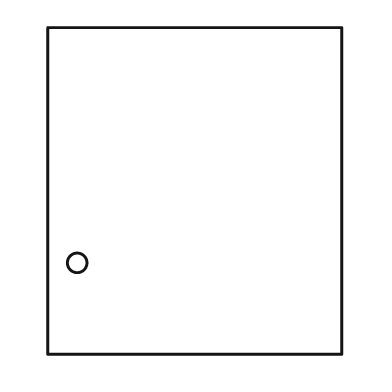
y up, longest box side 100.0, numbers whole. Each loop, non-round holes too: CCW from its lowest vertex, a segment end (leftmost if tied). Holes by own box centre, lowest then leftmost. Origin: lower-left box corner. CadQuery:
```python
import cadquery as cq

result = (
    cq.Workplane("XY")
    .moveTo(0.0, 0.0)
    .lineTo(90.0, 0.0)
    .lineTo(90.0, 100.0)
    .lineTo(0.0, 100.0)
    .close()
    .moveTo(9.0, 28.0)
    .circle(3.0)
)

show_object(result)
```